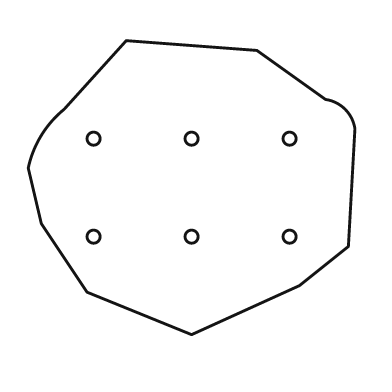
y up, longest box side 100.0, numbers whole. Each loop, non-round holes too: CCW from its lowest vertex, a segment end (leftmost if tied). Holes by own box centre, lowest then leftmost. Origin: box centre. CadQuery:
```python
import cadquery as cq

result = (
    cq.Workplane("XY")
    .moveTo(0.0, -45.0)
    .lineTo(33.0, -30.0)
    .lineTo(48.0, -18.0)
    .lineTo(50.0, 18.0)
    .threePointArc((47.0, 24.0), (41.0, 27.0))
    .lineTo(20.0, 42.0)
    .lineTo(-20.0, 45.0)
    .lineTo(-39.0, 24.0)
    .threePointArc((-46.0, 16.0), (-50.0, 6.0))
    .lineTo(-46.0, -11.0)
    .lineTo(-32.0, -32.0)
    .close()
    .moveTo(-30.0, -15.0)
    .circle(2.0)
    .moveTo(0.0, -15.0)
    .circle(2.0)
    .moveTo(30.0, -15.0)
    .circle(2.0)
    .moveTo(-30.0, 15.0)
    .circle(2.0)
    .moveTo(0.0, 15.0)
    .circle(2.0)
    .moveTo(30.0, 15.0)
    .circle(2.0)
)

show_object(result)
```